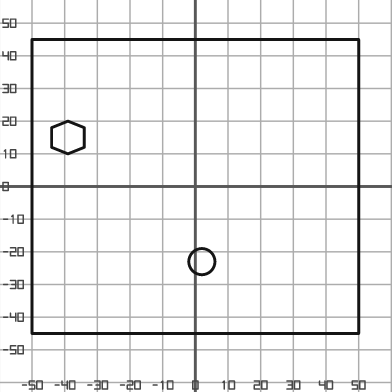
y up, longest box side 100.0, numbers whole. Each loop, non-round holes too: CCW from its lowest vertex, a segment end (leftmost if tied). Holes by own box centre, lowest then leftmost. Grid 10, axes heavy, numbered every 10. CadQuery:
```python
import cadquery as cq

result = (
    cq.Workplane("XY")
    .moveTo(-50.0, -45.0)
    .lineTo(50.0, -45.0)
    .lineTo(50.0, 45.0)
    .lineTo(-50.0, 45.0)
    .close()
    .moveTo(2.0, -23.0)
    .circle(4.0)
    .moveTo(-39.0, 10.0)
    .lineTo(-34.0, 12.0)
    .lineTo(-34.0, 18.0)
    .lineTo(-39.0, 20.0)
    .lineTo(-44.0, 18.0)
    .lineTo(-44.0, 12.0)
    .close()
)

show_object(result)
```